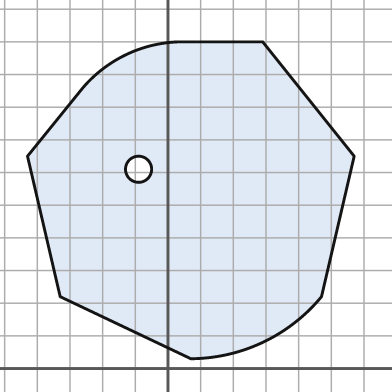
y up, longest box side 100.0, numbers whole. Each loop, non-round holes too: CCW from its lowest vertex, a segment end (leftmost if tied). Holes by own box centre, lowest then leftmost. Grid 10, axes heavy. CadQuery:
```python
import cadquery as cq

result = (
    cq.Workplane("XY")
    .moveTo(7.0, 3.0)
    .threePointArc((29.0, 8.0), (47.0, 22.0))
    .lineTo(57.0, 65.0)
    .lineTo(29.0, 100.0)
    .lineTo(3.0, 100.0)
    .threePointArc((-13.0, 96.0), (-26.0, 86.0))
    .lineTo(-43.0, 65.0)
    .lineTo(-33.0, 22.0)
    .close()
    .moveTo(-9.0, 61.0)
    .circle(4.0)
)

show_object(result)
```